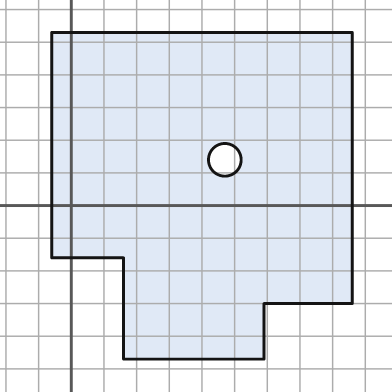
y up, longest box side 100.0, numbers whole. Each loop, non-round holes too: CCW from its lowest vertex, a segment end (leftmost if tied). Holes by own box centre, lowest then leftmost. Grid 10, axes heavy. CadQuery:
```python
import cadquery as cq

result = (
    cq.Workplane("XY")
    .moveTo(16.0, -47.0)
    .lineTo(59.0, -47.0)
    .lineTo(59.0, -30.0)
    .lineTo(86.0, -30.0)
    .lineTo(86.0, 53.0)
    .lineTo(-6.0, 53.0)
    .lineTo(-6.0, -16.0)
    .lineTo(16.0, -16.0)
    .close()
    .moveTo(47.0, 14.0)
    .circle(5.0)
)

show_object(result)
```